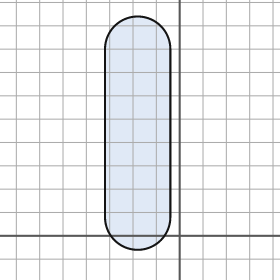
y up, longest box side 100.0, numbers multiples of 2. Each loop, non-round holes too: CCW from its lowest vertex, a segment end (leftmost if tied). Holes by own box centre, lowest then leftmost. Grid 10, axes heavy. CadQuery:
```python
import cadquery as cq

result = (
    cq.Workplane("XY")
    .moveTo(-32.0, 8.0)
    .threePointArc((-18.0, -6.0), (-4.0, 8.0))
    .lineTo(-4.0, 80.0)
    .threePointArc((-18.0, 94.0), (-32.0, 80.0))
    .close()
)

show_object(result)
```